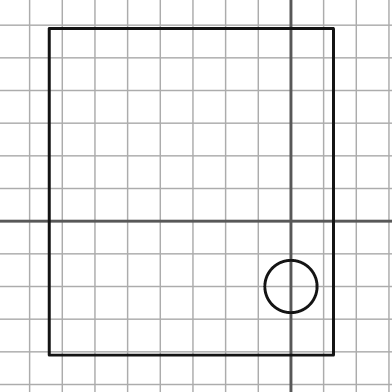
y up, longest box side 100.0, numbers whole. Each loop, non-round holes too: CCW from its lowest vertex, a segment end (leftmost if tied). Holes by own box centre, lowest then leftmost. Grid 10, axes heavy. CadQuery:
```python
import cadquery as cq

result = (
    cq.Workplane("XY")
    .moveTo(-74.0, -41.0)
    .lineTo(13.0, -41.0)
    .lineTo(13.0, 59.0)
    .lineTo(-74.0, 59.0)
    .close()
    .moveTo(0.0, -20.0)
    .circle(8.0)
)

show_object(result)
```